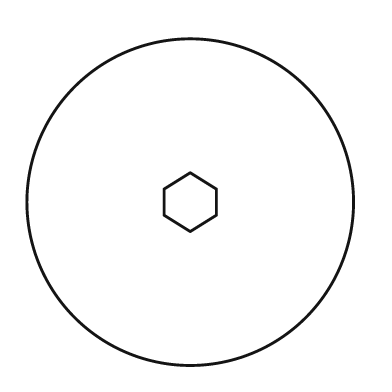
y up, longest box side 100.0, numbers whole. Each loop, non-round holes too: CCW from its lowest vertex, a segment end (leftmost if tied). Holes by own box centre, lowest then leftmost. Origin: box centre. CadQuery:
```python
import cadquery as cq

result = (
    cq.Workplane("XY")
    .moveTo(0.0, 0.0)
    .circle(50.0)
    .moveTo(0.0, -9.0)
    .lineTo(8.0, -4.0)
    .lineTo(8.0, 4.0)
    .lineTo(0.0, 9.0)
    .lineTo(-8.0, 4.0)
    .lineTo(-8.0, -4.0)
    .close()
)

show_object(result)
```